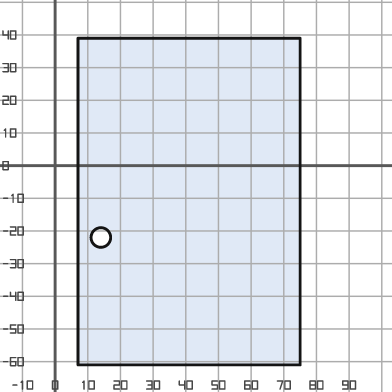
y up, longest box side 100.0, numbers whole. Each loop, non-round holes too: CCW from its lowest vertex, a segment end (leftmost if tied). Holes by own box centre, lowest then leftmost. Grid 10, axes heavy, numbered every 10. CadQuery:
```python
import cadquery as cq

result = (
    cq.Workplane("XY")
    .moveTo(7.0, -61.0)
    .lineTo(75.0, -61.0)
    .lineTo(75.0, 39.0)
    .lineTo(7.0, 39.0)
    .close()
    .moveTo(14.0, -22.0)
    .circle(3.0)
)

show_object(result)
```